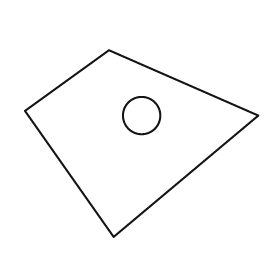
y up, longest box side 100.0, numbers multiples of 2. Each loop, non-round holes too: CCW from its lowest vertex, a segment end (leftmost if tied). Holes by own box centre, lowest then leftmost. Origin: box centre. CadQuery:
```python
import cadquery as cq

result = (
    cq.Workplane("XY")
    .moveTo(-12.0, -40.0)
    .lineTo(50.0, 12.0)
    .lineTo(-14.0, 40.0)
    .lineTo(-50.0, 14.0)
    .close()
    .moveTo(0.0, 12.0)
    .circle(8.0)
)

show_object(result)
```